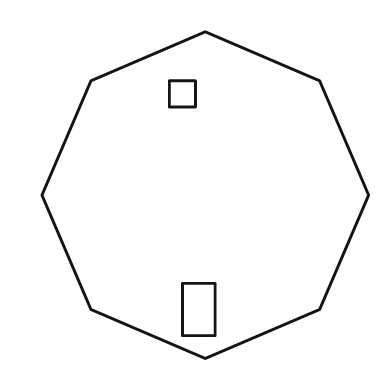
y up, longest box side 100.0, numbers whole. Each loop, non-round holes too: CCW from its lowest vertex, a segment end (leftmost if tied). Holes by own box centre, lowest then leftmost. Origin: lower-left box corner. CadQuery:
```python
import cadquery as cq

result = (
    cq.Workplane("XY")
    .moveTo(50.0, 0.0)
    .lineTo(85.0, 15.0)
    .lineTo(100.0, 50.0)
    .lineTo(85.0, 85.0)
    .lineTo(50.0, 100.0)
    .lineTo(15.0, 85.0)
    .lineTo(0.0, 50.0)
    .lineTo(15.0, 15.0)
    .close()
    .moveTo(43.0, 7.0)
    .lineTo(53.0, 7.0)
    .lineTo(53.0, 23.0)
    .lineTo(43.0, 23.0)
    .close()
    .moveTo(39.0, 77.0)
    .lineTo(47.0, 77.0)
    .lineTo(47.0, 85.0)
    .lineTo(39.0, 85.0)
    .close()
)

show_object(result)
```